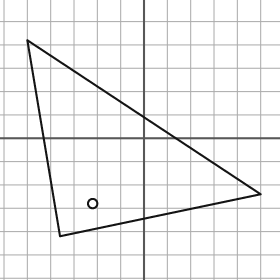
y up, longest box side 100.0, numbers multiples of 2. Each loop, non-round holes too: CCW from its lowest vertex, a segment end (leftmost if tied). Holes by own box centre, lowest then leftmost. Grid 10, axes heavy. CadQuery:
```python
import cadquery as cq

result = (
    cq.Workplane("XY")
    .moveTo(-36.0, -42.0)
    .lineTo(50.0, -24.0)
    .lineTo(-50.0, 42.0)
    .close()
    .moveTo(-22.0, -28.0)
    .circle(2.0)
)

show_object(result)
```